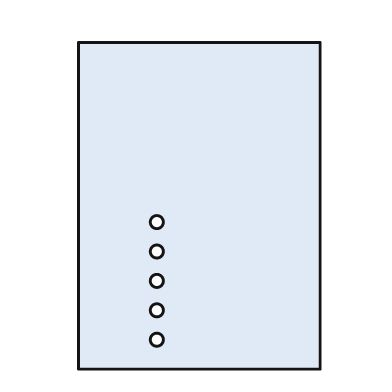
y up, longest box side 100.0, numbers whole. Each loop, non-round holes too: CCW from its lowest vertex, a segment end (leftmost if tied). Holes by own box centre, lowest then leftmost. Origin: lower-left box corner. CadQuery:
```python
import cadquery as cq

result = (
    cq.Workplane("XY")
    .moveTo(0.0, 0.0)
    .lineTo(74.0, 0.0)
    .lineTo(74.0, 100.0)
    .lineTo(0.0, 100.0)
    .close()
    .moveTo(24.0, 9.0)
    .circle(2.0)
    .moveTo(24.0, 18.0)
    .circle(2.0)
    .moveTo(24.0, 27.0)
    .circle(2.0)
    .moveTo(24.0, 36.0)
    .circle(2.0)
    .moveTo(24.0, 45.0)
    .circle(2.0)
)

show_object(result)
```